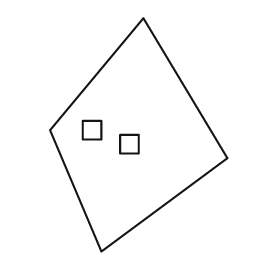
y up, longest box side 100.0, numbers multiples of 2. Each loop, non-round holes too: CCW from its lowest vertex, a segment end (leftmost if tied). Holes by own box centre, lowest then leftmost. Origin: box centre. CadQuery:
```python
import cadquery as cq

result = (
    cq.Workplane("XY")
    .moveTo(-16.0, -50.0)
    .lineTo(38.0, -10.0)
    .lineTo(2.0, 50.0)
    .lineTo(-38.0, 2.0)
    .close()
    .moveTo(-8.0, -8.0)
    .lineTo(0.0, -8.0)
    .lineTo(0.0, 0.0)
    .lineTo(-8.0, 0.0)
    .close()
    .moveTo(-24.0, -2.0)
    .lineTo(-16.0, -2.0)
    .lineTo(-16.0, 6.0)
    .lineTo(-24.0, 6.0)
    .close()
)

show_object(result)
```